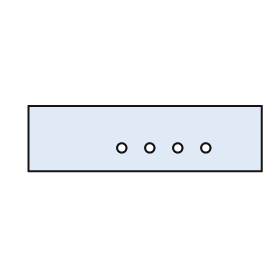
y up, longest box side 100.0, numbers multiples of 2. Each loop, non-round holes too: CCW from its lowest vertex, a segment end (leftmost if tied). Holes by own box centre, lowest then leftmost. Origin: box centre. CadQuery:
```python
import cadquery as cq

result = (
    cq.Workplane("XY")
    .moveTo(-50.0, -14.0)
    .lineTo(50.0, -14.0)
    .lineTo(50.0, 14.0)
    .lineTo(-50.0, 14.0)
    .close()
    .moveTo(-10.0, -4.0)
    .circle(2.0)
    .moveTo(2.0, -4.0)
    .circle(2.0)
    .moveTo(14.0, -4.0)
    .circle(2.0)
    .moveTo(26.0, -4.0)
    .circle(2.0)
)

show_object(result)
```